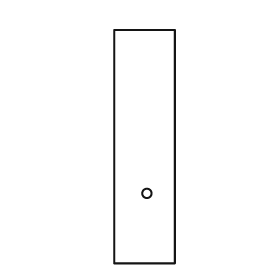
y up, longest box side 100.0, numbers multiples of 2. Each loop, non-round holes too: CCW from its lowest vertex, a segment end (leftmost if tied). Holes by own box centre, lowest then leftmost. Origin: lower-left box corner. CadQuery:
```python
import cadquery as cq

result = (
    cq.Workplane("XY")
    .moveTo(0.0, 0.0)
    .lineTo(26.0, 0.0)
    .lineTo(26.0, 100.0)
    .lineTo(0.0, 100.0)
    .close()
    .moveTo(14.0, 30.0)
    .circle(2.0)
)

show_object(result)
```